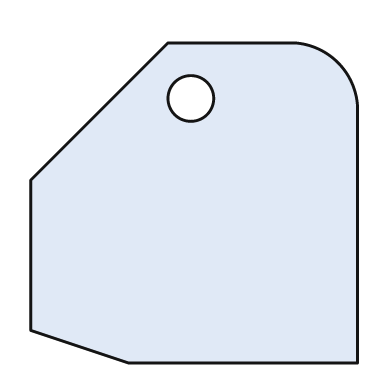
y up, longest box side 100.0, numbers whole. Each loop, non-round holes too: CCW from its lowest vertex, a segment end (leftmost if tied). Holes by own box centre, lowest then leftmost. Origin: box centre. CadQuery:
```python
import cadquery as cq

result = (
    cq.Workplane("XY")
    .moveTo(-20.0, -49.0)
    .lineTo(50.0, -49.0)
    .lineTo(50.0, 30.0)
    .threePointArc((44.0, 43.0), (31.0, 49.0))
    .lineTo(-8.0, 49.0)
    .lineTo(-50.0, 7.0)
    .lineTo(-50.0, -39.0)
    .close()
    .moveTo(-1.0, 32.0)
    .circle(7.0)
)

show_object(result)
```